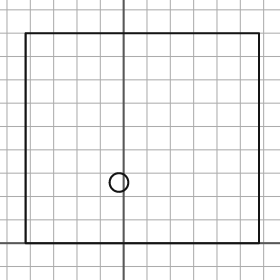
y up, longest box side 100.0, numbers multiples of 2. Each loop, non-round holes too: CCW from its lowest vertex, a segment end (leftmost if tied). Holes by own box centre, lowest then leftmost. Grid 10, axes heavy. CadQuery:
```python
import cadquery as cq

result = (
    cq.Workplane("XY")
    .moveTo(-42.0, 0.0)
    .lineTo(58.0, 0.0)
    .lineTo(58.0, 90.0)
    .lineTo(-42.0, 90.0)
    .close()
    .moveTo(-2.0, 26.0)
    .circle(4.0)
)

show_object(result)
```